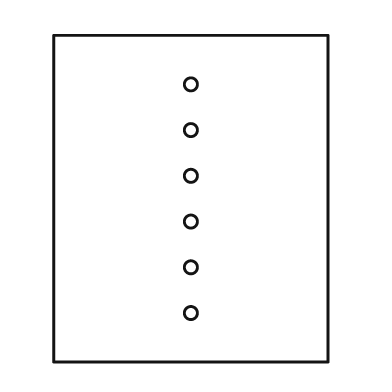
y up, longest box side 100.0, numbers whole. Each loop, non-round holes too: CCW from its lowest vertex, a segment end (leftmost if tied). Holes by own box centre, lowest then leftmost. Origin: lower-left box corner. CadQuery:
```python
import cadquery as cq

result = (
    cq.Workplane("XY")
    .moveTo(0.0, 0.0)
    .lineTo(84.0, 0.0)
    .lineTo(84.0, 100.0)
    .lineTo(0.0, 100.0)
    .close()
    .moveTo(42.0, 15.0)
    .circle(2.0)
    .moveTo(42.0, 29.0)
    .circle(2.0)
    .moveTo(42.0, 43.0)
    .circle(2.0)
    .moveTo(42.0, 57.0)
    .circle(2.0)
    .moveTo(42.0, 71.0)
    .circle(2.0)
    .moveTo(42.0, 85.0)
    .circle(2.0)
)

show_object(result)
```